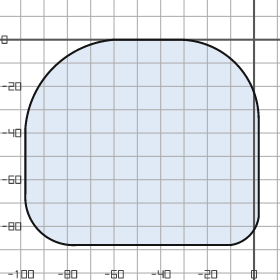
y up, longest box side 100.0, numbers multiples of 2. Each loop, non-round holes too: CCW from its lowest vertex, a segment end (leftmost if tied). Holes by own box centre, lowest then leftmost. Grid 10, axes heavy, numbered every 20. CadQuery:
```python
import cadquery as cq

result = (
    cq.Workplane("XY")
    .moveTo(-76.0, -88.0)
    .lineTo(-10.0, -88.0)
    .threePointArc((-2.0, -84.0), (2.0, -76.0))
    .lineTo(2.0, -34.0)
    .threePointArc((-8.0, -10.0), (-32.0, 0.0))
    .lineTo(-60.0, 0.0)
    .threePointArc((-86.0, -12.0), (-98.0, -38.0))
    .lineTo(-98.0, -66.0)
    .threePointArc((-92.0, -82.0), (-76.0, -88.0))
    .close()
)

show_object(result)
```